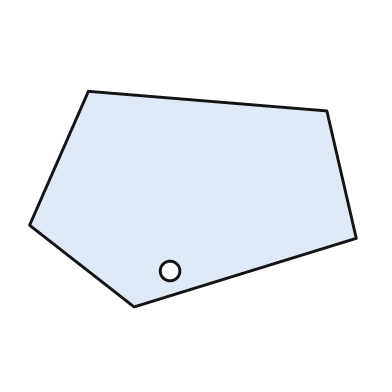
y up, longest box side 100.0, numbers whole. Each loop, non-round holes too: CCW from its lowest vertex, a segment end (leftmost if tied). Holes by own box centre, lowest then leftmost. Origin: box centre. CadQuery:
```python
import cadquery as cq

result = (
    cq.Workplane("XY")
    .moveTo(-18.0, -33.0)
    .lineTo(50.0, -12.0)
    .lineTo(41.0, 27.0)
    .lineTo(-32.0, 33.0)
    .lineTo(-50.0, -8.0)
    .close()
    .moveTo(-7.0, -22.0)
    .circle(3.0)
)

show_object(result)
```